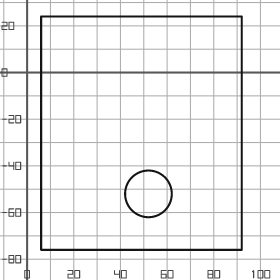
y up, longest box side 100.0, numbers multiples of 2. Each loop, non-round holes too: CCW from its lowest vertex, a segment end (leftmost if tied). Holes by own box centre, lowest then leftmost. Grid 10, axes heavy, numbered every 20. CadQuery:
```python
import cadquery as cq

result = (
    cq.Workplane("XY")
    .moveTo(6.0, -76.0)
    .lineTo(92.0, -76.0)
    .lineTo(92.0, 24.0)
    .lineTo(6.0, 24.0)
    .close()
    .moveTo(52.0, -52.0)
    .circle(10.0)
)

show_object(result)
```